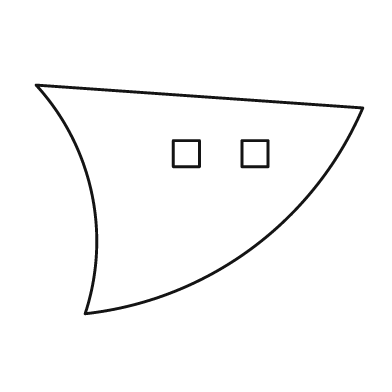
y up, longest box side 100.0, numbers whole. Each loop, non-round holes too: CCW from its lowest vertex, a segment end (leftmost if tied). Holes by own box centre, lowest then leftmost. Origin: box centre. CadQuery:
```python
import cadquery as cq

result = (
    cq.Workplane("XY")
    .moveTo(-35.0, -35.0)
    .threePointArc((16.0, -15.0), (50.0, 28.0))
    .lineTo(-50.0, 35.0)
    .threePointArc((-33.0, 2.0), (-35.0, -35.0))
    .close()
    .moveTo(-8.0, 10.0)
    .lineTo(0.0, 10.0)
    .lineTo(0.0, 18.0)
    .lineTo(-8.0, 18.0)
    .close()
    .moveTo(13.0, 10.0)
    .lineTo(21.0, 10.0)
    .lineTo(21.0, 18.0)
    .lineTo(13.0, 18.0)
    .close()
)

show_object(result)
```